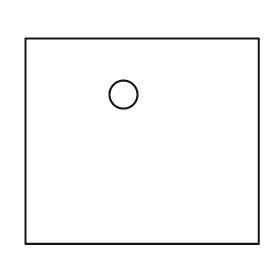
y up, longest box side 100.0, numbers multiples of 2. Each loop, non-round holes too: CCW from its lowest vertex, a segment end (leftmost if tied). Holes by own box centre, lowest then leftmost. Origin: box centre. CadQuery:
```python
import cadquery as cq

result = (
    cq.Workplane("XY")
    .moveTo(-50.0, -44.0)
    .lineTo(50.0, -44.0)
    .lineTo(50.0, 44.0)
    .lineTo(-50.0, 44.0)
    .close()
    .moveTo(-8.0, 20.0)
    .circle(6.0)
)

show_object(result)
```